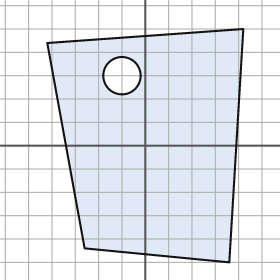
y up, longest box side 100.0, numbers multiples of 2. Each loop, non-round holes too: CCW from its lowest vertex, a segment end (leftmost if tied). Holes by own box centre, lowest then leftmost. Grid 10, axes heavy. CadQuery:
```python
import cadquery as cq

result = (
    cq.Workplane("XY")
    .moveTo(36.0, -50.0)
    .lineTo(42.0, 50.0)
    .lineTo(-42.0, 44.0)
    .lineTo(-26.0, -44.0)
    .close()
    .moveTo(-10.0, 30.0)
    .circle(8.0)
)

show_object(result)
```